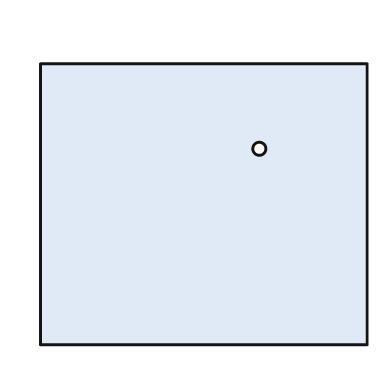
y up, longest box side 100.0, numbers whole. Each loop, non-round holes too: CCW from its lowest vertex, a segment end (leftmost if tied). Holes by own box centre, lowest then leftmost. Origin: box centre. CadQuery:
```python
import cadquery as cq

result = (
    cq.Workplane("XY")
    .moveTo(-50.0, -43.0)
    .lineTo(50.0, -43.0)
    .lineTo(50.0, 43.0)
    .lineTo(-50.0, 43.0)
    .close()
    .moveTo(17.0, 17.0)
    .circle(2.0)
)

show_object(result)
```